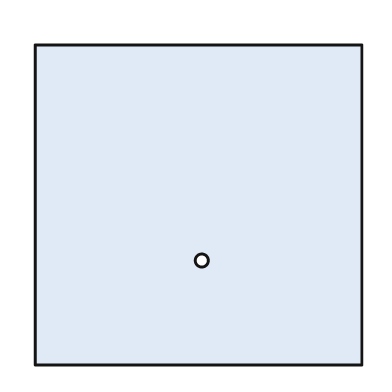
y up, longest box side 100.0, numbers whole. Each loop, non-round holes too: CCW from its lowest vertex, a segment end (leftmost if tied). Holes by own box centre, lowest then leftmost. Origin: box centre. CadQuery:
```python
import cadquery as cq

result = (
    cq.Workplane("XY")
    .moveTo(-50.0, -49.0)
    .lineTo(50.0, -49.0)
    .lineTo(50.0, 49.0)
    .lineTo(-50.0, 49.0)
    .close()
    .moveTo(1.0, -17.0)
    .circle(2.0)
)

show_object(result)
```